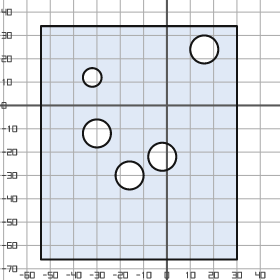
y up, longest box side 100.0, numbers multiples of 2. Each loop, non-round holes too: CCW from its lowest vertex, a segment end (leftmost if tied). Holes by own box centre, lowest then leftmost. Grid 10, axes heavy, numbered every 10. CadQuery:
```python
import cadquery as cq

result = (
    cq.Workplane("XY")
    .moveTo(-54.0, -66.0)
    .lineTo(30.0, -66.0)
    .lineTo(30.0, 34.0)
    .lineTo(-54.0, 34.0)
    .close()
    .moveTo(-16.0, -30.0)
    .circle(6.0)
    .moveTo(-2.0, -22.0)
    .circle(6.0)
    .moveTo(-30.0, -12.0)
    .circle(6.0)
    .moveTo(-32.0, 12.0)
    .circle(4.0)
    .moveTo(16.0, 24.0)
    .circle(6.0)
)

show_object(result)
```